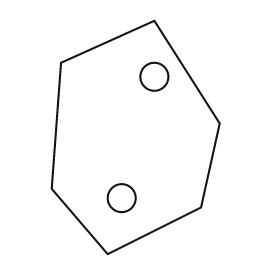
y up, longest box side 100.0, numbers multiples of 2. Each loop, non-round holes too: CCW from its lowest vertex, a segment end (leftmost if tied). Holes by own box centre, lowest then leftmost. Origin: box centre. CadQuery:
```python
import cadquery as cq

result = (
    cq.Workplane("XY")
    .moveTo(-12.0, -50.0)
    .lineTo(28.0, -30.0)
    .lineTo(36.0, 6.0)
    .lineTo(8.0, 50.0)
    .lineTo(-32.0, 32.0)
    .lineTo(-36.0, -22.0)
    .close()
    .moveTo(-6.0, -26.0)
    .circle(6.0)
    .moveTo(8.0, 26.0)
    .circle(6.0)
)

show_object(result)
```